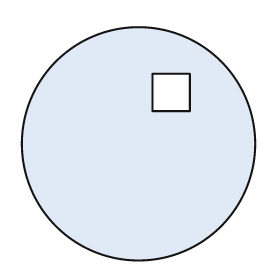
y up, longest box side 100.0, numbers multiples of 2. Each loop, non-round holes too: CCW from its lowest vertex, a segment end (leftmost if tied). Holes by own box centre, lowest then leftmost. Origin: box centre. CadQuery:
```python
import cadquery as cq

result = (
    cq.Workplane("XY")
    .moveTo(0.0, 0.0)
    .circle(50.0)
    .moveTo(6.0, 14.0)
    .lineTo(22.0, 14.0)
    .lineTo(22.0, 30.0)
    .lineTo(6.0, 30.0)
    .close()
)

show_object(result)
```